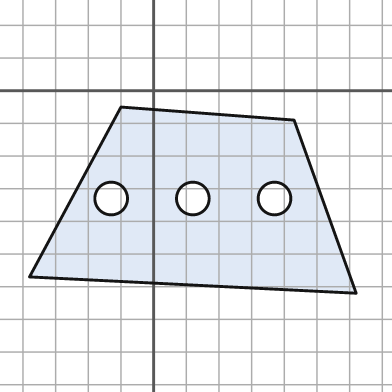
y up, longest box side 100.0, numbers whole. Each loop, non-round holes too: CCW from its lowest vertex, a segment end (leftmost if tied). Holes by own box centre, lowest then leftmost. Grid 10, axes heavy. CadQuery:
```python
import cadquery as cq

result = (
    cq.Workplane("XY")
    .moveTo(62.0, -62.0)
    .lineTo(43.0, -9.0)
    .lineTo(-10.0, -5.0)
    .lineTo(-38.0, -57.0)
    .close()
    .moveTo(-13.0, -33.0)
    .circle(5.0)
    .moveTo(12.0, -33.0)
    .circle(5.0)
    .moveTo(37.0, -33.0)
    .circle(5.0)
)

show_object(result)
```